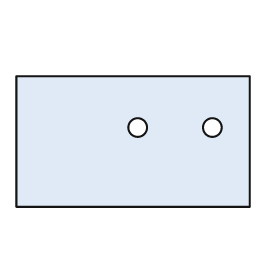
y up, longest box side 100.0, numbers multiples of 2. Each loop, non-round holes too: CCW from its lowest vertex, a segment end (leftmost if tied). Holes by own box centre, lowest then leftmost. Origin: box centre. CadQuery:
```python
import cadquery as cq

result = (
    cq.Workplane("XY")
    .moveTo(-50.0, -28.0)
    .lineTo(50.0, -28.0)
    .lineTo(50.0, 28.0)
    .lineTo(-50.0, 28.0)
    .close()
    .moveTo(2.0, 6.0)
    .circle(4.0)
    .moveTo(34.0, 6.0)
    .circle(4.0)
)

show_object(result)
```